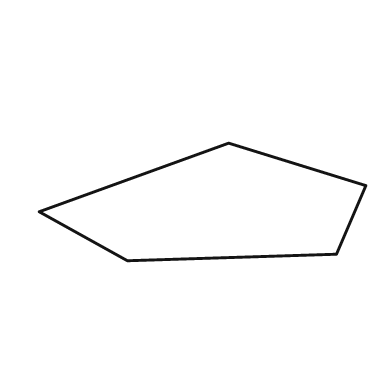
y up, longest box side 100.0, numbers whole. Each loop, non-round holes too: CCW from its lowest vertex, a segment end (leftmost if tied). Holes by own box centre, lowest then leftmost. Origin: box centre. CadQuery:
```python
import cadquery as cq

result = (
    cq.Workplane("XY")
    .moveTo(-23.0, -18.0)
    .lineTo(41.0, -16.0)
    .lineTo(50.0, 5.0)
    .lineTo(8.0, 18.0)
    .lineTo(-50.0, -3.0)
    .close()
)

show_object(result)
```